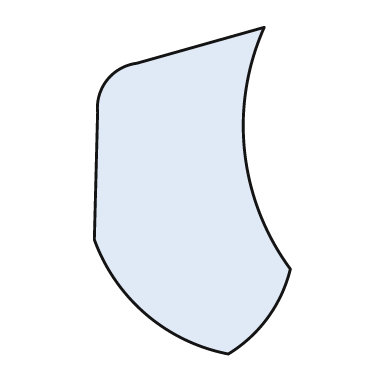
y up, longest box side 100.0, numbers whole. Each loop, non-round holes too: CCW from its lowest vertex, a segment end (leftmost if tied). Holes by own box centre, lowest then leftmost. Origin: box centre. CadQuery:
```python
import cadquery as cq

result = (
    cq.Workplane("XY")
    .moveTo(11.0, -50.0)
    .threePointArc((23.0, -39.0), (30.0, -24.0))
    .threePointArc((16.0, 12.0), (22.0, 50.0))
    .lineTo(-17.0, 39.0)
    .threePointArc((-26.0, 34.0), (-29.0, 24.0))
    .lineTo(-30.0, -15.0)
    .threePointArc((-14.0, -38.0), (11.0, -50.0))
    .close()
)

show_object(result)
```